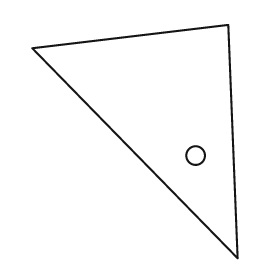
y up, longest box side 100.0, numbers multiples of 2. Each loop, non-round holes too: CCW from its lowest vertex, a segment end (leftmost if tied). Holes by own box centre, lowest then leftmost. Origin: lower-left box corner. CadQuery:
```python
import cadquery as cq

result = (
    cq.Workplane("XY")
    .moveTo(88.0, 0.0)
    .lineTo(84.0, 100.0)
    .lineTo(0.0, 90.0)
    .close()
    .moveTo(70.0, 44.0)
    .circle(4.0)
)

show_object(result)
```